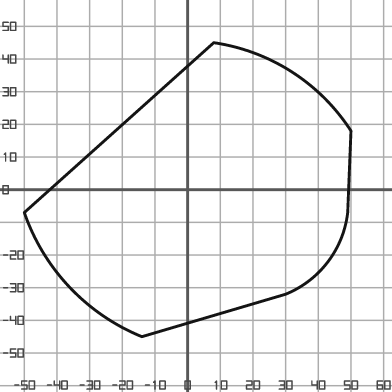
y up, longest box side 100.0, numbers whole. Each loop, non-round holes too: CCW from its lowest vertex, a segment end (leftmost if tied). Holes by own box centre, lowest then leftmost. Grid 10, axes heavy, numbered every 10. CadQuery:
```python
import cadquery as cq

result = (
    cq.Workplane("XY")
    .moveTo(-14.0, -45.0)
    .lineTo(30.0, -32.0)
    .threePointArc((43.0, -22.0), (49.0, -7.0))
    .lineTo(50.0, 18.0)
    .threePointArc((32.0, 36.0), (8.0, 45.0))
    .lineTo(-50.0, -7.0)
    .threePointArc((-36.0, -30.0), (-14.0, -45.0))
    .close()
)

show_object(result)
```